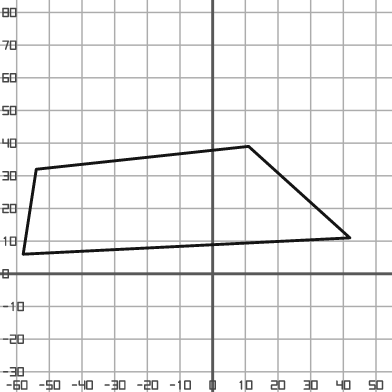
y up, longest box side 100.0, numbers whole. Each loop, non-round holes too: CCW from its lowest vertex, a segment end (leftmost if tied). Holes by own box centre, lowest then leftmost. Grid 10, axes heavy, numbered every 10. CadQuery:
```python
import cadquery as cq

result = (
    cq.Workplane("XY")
    .moveTo(-58.0, 6.0)
    .lineTo(42.0, 11.0)
    .lineTo(11.0, 39.0)
    .lineTo(-54.0, 32.0)
    .close()
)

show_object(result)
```